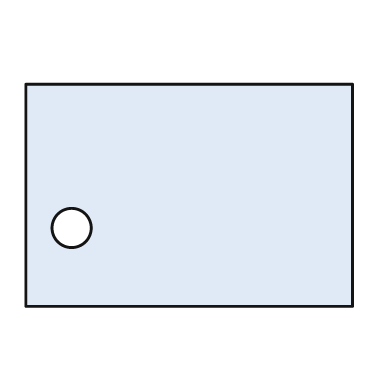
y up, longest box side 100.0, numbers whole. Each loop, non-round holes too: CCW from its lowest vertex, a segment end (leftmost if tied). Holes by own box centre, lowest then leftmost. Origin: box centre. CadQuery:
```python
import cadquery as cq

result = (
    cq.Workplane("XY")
    .moveTo(-50.0, -34.0)
    .lineTo(50.0, -34.0)
    .lineTo(50.0, 34.0)
    .lineTo(-50.0, 34.0)
    .close()
    .moveTo(-36.0, -10.0)
    .circle(6.0)
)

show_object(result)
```